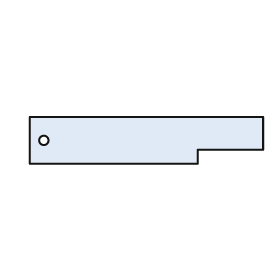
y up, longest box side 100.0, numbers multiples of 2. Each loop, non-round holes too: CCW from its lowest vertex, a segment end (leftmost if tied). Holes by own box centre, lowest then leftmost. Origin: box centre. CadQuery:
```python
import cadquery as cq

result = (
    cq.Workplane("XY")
    .moveTo(-50.0, -10.0)
    .lineTo(22.0, -10.0)
    .lineTo(22.0, -4.0)
    .lineTo(50.0, -4.0)
    .lineTo(50.0, 10.0)
    .lineTo(-50.0, 10.0)
    .close()
    .moveTo(-44.0, 0.0)
    .circle(2.0)
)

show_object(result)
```